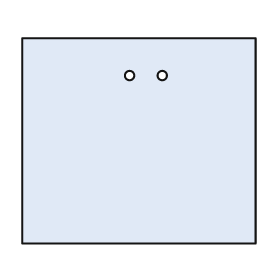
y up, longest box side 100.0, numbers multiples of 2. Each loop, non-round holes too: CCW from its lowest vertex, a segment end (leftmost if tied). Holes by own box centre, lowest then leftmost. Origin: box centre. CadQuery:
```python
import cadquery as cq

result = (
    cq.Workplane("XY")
    .moveTo(-50.0, -44.0)
    .lineTo(50.0, -44.0)
    .lineTo(50.0, 44.0)
    .lineTo(-50.0, 44.0)
    .close()
    .moveTo(-4.0, 28.0)
    .circle(2.0)
    .moveTo(10.0, 28.0)
    .circle(2.0)
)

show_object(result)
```